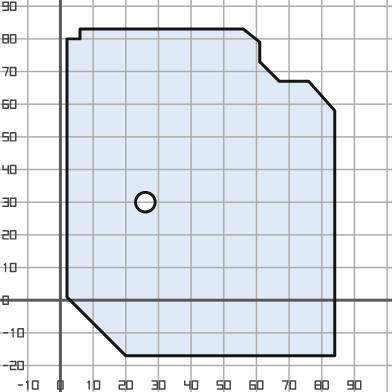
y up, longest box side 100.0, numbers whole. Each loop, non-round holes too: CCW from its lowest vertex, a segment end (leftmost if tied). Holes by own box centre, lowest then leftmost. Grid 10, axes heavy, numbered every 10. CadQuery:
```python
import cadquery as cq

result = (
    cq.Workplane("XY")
    .moveTo(20.0, -17.0)
    .lineTo(84.0, -17.0)
    .lineTo(84.0, 58.0)
    .lineTo(76.0, 67.0)
    .lineTo(67.0, 67.0)
    .lineTo(61.0, 73.0)
    .lineTo(61.0, 79.0)
    .lineTo(56.0, 83.0)
    .lineTo(6.0, 83.0)
    .lineTo(6.0, 80.0)
    .lineTo(2.0, 80.0)
    .lineTo(2.0, 1.0)
    .close()
    .moveTo(26.0, 30.0)
    .circle(3.0)
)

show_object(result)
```